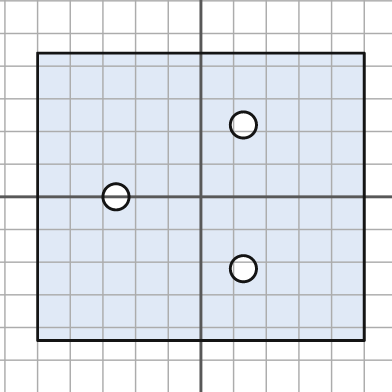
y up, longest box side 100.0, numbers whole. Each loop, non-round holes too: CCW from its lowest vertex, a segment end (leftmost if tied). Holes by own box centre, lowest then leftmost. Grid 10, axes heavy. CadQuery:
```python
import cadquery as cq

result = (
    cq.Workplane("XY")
    .moveTo(-50.0, -44.0)
    .lineTo(50.0, -44.0)
    .lineTo(50.0, 44.0)
    .lineTo(-50.0, 44.0)
    .close()
    .moveTo(13.0, -22.0)
    .circle(4.0)
    .moveTo(-26.0, 0.0)
    .circle(4.0)
    .moveTo(13.0, 22.0)
    .circle(4.0)
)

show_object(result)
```